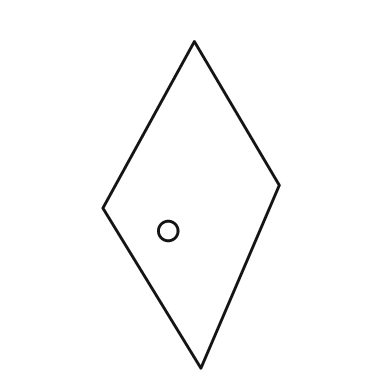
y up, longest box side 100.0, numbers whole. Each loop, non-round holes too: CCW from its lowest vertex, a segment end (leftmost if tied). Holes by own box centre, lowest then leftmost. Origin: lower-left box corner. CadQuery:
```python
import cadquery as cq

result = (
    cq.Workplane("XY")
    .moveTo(30.0, 0.0)
    .lineTo(54.0, 56.0)
    .lineTo(28.0, 100.0)
    .lineTo(0.0, 49.0)
    .close()
    .moveTo(20.0, 42.0)
    .circle(3.0)
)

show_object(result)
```